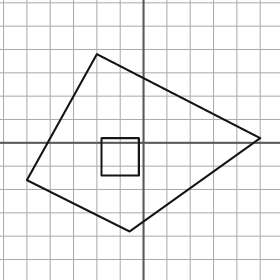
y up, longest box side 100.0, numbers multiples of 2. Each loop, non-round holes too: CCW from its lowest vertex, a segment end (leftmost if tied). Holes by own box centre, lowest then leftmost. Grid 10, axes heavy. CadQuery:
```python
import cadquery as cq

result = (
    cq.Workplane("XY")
    .moveTo(-6.0, -38.0)
    .lineTo(50.0, 2.0)
    .lineTo(-20.0, 38.0)
    .lineTo(-50.0, -16.0)
    .close()
    .moveTo(-18.0, -14.0)
    .lineTo(-2.0, -14.0)
    .lineTo(-2.0, 2.0)
    .lineTo(-18.0, 2.0)
    .close()
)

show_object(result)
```